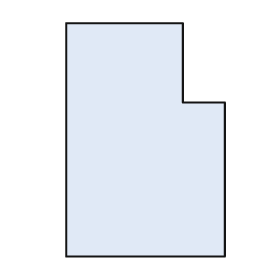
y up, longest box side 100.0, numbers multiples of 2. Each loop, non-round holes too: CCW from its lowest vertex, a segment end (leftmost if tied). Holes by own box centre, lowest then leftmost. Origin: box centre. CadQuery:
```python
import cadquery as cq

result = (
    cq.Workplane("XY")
    .moveTo(-34.0, -50.0)
    .lineTo(34.0, -50.0)
    .lineTo(34.0, 16.0)
    .lineTo(16.0, 16.0)
    .lineTo(16.0, 50.0)
    .lineTo(-34.0, 50.0)
    .close()
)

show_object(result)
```